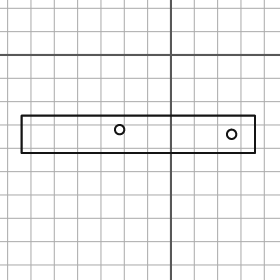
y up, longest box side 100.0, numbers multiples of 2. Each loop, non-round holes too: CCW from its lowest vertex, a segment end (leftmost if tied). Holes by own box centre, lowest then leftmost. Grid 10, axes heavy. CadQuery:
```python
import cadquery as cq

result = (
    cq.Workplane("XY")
    .moveTo(-64.0, -42.0)
    .lineTo(36.0, -42.0)
    .lineTo(36.0, -26.0)
    .lineTo(-64.0, -26.0)
    .close()
    .moveTo(26.0, -34.0)
    .circle(2.0)
    .moveTo(-22.0, -32.0)
    .circle(2.0)
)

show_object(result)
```